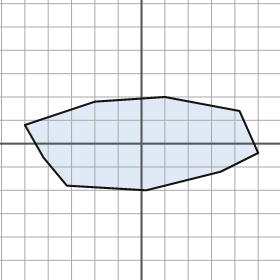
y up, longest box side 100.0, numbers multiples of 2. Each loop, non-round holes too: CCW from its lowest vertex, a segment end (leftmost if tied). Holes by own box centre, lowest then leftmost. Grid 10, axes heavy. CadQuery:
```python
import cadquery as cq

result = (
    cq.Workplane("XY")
    .moveTo(2.0, -20.0)
    .lineTo(34.0, -12.0)
    .lineTo(50.0, -4.0)
    .lineTo(42.0, 14.0)
    .lineTo(10.0, 20.0)
    .lineTo(-20.0, 18.0)
    .lineTo(-50.0, 8.0)
    .lineTo(-42.0, -6.0)
    .lineTo(-32.0, -18.0)
    .close()
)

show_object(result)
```